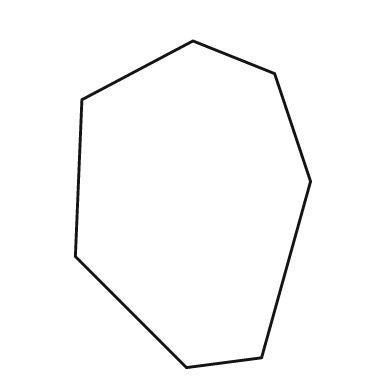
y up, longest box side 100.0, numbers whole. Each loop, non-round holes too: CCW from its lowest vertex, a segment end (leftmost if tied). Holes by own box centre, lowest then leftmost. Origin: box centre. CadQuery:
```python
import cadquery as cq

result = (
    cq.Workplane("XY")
    .moveTo(-2.0, -50.0)
    .lineTo(21.0, -47.0)
    .lineTo(36.0, 7.0)
    .lineTo(25.0, 40.0)
    .lineTo(0.0, 50.0)
    .lineTo(-34.0, 32.0)
    .lineTo(-36.0, -16.0)
    .close()
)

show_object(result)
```